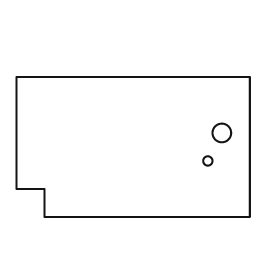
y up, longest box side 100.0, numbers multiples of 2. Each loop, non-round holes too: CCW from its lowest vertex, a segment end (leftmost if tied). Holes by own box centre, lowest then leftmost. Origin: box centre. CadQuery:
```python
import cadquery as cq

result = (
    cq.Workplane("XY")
    .moveTo(-38.0, -30.0)
    .lineTo(50.0, -30.0)
    .lineTo(50.0, 30.0)
    .lineTo(-50.0, 30.0)
    .lineTo(-50.0, -18.0)
    .lineTo(-38.0, -18.0)
    .close()
    .moveTo(32.0, -6.0)
    .circle(2.0)
    .moveTo(38.0, 6.0)
    .circle(4.0)
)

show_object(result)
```